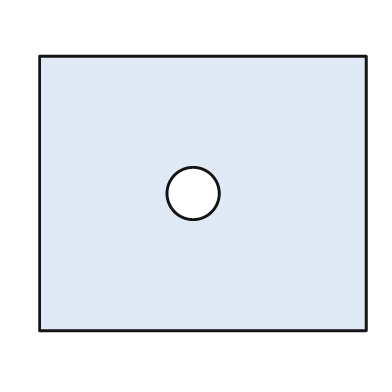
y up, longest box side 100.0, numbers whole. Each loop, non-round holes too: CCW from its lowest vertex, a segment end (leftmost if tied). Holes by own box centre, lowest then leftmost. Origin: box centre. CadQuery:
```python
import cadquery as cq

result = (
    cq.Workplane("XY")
    .moveTo(-50.0, -42.0)
    .lineTo(50.0, -42.0)
    .lineTo(50.0, 42.0)
    .lineTo(-50.0, 42.0)
    .close()
    .moveTo(-3.0, 0.0)
    .circle(8.0)
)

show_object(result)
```